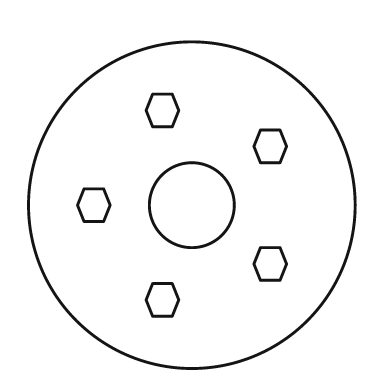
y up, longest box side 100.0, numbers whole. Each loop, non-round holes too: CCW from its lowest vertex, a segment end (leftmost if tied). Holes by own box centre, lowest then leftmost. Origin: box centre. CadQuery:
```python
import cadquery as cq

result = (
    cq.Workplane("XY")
    .moveTo(0.0, 0.0)
    .circle(50.0)
    .moveTo(-12.0, -34.0)
    .lineTo(-6.0, -34.0)
    .lineTo(-4.0, -29.0)
    .lineTo(-6.0, -24.0)
    .lineTo(-12.0, -24.0)
    .lineTo(-14.0, -29.0)
    .close()
    .moveTo(21.0, -23.0)
    .lineTo(27.0, -23.0)
    .lineTo(29.0, -18.0)
    .lineTo(27.0, -13.0)
    .lineTo(21.0, -13.0)
    .lineTo(19.0, -18.0)
    .close()
    .moveTo(-33.0, -5.0)
    .lineTo(-27.0, -5.0)
    .lineTo(-25.0, 0.0)
    .lineTo(-27.0, 5.0)
    .lineTo(-33.0, 5.0)
    .lineTo(-35.0, 0.0)
    .close()
    .moveTo(0.0, 0.0)
    .circle(13.0)
    .moveTo(21.0, 13.0)
    .lineTo(27.0, 13.0)
    .lineTo(29.0, 18.0)
    .lineTo(27.0, 23.0)
    .lineTo(21.0, 23.0)
    .lineTo(19.0, 18.0)
    .close()
    .moveTo(-12.0, 24.0)
    .lineTo(-6.0, 24.0)
    .lineTo(-4.0, 29.0)
    .lineTo(-6.0, 34.0)
    .lineTo(-12.0, 34.0)
    .lineTo(-14.0, 29.0)
    .close()
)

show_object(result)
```